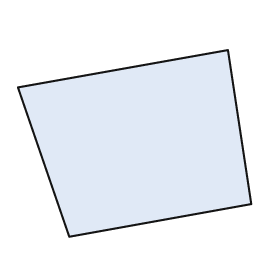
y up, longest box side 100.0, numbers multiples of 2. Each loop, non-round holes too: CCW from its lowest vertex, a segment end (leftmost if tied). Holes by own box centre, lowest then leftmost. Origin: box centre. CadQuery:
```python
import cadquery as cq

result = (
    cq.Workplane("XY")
    .moveTo(-28.0, -40.0)
    .lineTo(50.0, -26.0)
    .lineTo(40.0, 40.0)
    .lineTo(-50.0, 24.0)
    .close()
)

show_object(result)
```